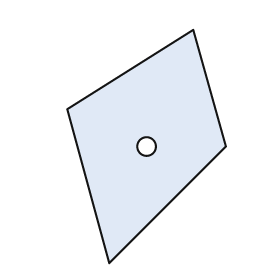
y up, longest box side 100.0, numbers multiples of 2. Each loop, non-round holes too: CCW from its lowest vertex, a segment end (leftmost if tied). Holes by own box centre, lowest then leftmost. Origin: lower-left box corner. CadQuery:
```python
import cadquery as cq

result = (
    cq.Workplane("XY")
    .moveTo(18.0, 0.0)
    .lineTo(68.0, 50.0)
    .lineTo(54.0, 100.0)
    .lineTo(0.0, 66.0)
    .close()
    .moveTo(34.0, 50.0)
    .circle(4.0)
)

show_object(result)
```